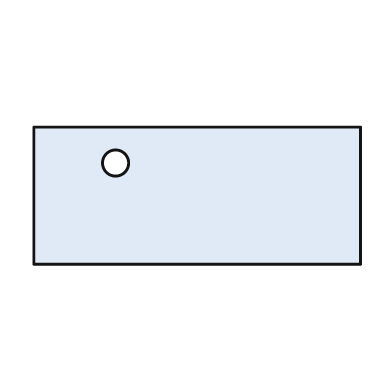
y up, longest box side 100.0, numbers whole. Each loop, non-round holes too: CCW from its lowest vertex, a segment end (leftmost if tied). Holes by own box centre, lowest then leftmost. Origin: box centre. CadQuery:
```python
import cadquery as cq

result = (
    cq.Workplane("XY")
    .moveTo(-50.0, -21.0)
    .lineTo(50.0, -21.0)
    .lineTo(50.0, 21.0)
    .lineTo(-50.0, 21.0)
    .close()
    .moveTo(-25.0, 10.0)
    .circle(4.0)
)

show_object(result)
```